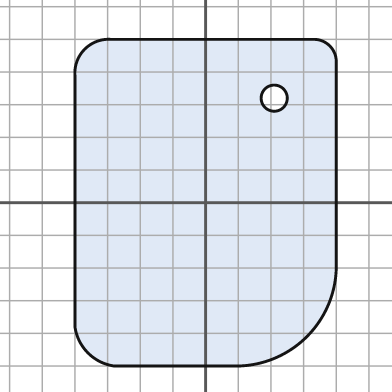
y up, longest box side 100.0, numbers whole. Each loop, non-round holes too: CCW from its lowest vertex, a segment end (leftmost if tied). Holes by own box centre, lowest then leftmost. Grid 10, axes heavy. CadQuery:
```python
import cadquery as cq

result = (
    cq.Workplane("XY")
    .moveTo(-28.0, -50.0)
    .lineTo(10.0, -50.0)
    .threePointArc((31.0, -41.0), (40.0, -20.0))
    .lineTo(40.0, 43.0)
    .threePointArc((38.0, 48.0), (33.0, 50.0))
    .lineTo(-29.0, 50.0)
    .threePointArc((-37.0, 47.0), (-40.0, 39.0))
    .lineTo(-40.0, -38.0)
    .threePointArc((-36.0, -46.0), (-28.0, -50.0))
    .close()
    .moveTo(21.0, 32.0)
    .circle(4.0)
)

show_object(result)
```